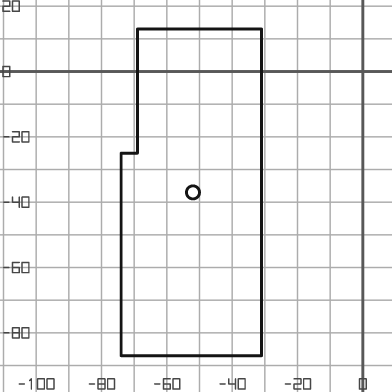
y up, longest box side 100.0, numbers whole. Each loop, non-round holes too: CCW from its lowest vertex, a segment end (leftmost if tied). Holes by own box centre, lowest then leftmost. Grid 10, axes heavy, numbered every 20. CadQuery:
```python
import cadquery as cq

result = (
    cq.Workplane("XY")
    .moveTo(-74.0, -87.0)
    .lineTo(-31.0, -87.0)
    .lineTo(-31.0, 13.0)
    .lineTo(-69.0, 13.0)
    .lineTo(-69.0, -25.0)
    .lineTo(-74.0, -25.0)
    .close()
    .moveTo(-52.0, -37.0)
    .circle(2.0)
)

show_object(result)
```